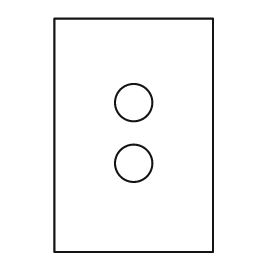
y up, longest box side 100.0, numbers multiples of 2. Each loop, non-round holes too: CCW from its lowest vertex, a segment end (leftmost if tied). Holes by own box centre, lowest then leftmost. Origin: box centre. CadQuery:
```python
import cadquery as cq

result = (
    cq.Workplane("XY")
    .moveTo(-34.0, -50.0)
    .lineTo(34.0, -50.0)
    .lineTo(34.0, 50.0)
    .lineTo(-34.0, 50.0)
    .close()
    .moveTo(0.0, -12.0)
    .circle(8.0)
    .moveTo(0.0, 14.0)
    .circle(8.0)
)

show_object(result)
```